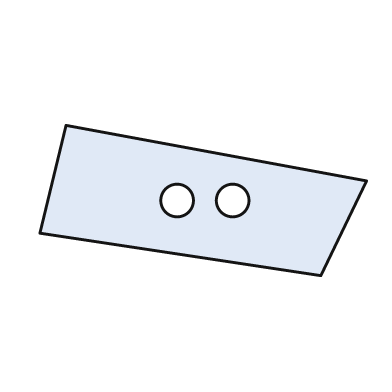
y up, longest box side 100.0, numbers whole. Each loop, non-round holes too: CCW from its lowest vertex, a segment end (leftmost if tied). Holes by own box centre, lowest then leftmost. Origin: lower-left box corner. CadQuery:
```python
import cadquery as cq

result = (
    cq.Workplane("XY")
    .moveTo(86.0, 0.0)
    .lineTo(100.0, 29.0)
    .lineTo(8.0, 46.0)
    .lineTo(0.0, 13.0)
    .close()
    .moveTo(42.0, 23.0)
    .circle(5.0)
    .moveTo(59.0, 23.0)
    .circle(5.0)
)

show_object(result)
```